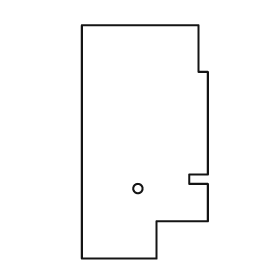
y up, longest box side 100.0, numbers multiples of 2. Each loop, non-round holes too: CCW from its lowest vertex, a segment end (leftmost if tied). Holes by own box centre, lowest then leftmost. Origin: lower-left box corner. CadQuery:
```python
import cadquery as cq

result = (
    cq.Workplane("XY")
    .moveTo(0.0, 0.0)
    .lineTo(32.0, 0.0)
    .lineTo(32.0, 16.0)
    .lineTo(54.0, 16.0)
    .lineTo(54.0, 32.0)
    .lineTo(46.0, 32.0)
    .lineTo(46.0, 36.0)
    .lineTo(54.0, 36.0)
    .lineTo(54.0, 80.0)
    .lineTo(50.0, 80.0)
    .lineTo(50.0, 100.0)
    .lineTo(0.0, 100.0)
    .close()
    .moveTo(24.0, 30.0)
    .circle(2.0)
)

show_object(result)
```